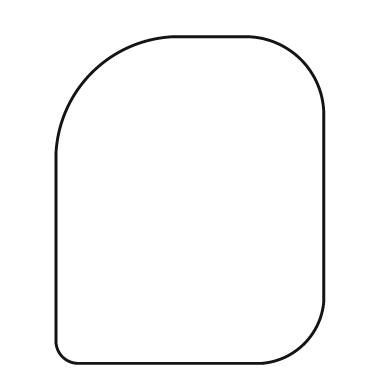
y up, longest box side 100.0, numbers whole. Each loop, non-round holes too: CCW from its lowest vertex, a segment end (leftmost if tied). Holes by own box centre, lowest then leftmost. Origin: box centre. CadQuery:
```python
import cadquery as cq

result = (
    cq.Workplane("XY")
    .moveTo(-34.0, -50.0)
    .lineTo(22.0, -50.0)
    .threePointArc((35.0, -44.0), (41.0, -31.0))
    .lineTo(41.0, 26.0)
    .threePointArc((34.0, 43.0), (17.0, 50.0))
    .lineTo(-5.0, 50.0)
    .threePointArc((-30.0, 39.0), (-41.0, 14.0))
    .lineTo(-41.0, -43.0)
    .threePointArc((-39.0, -48.0), (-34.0, -50.0))
    .close()
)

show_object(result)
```